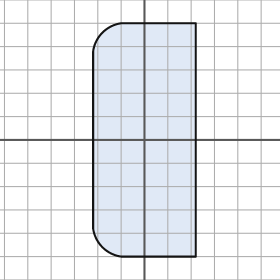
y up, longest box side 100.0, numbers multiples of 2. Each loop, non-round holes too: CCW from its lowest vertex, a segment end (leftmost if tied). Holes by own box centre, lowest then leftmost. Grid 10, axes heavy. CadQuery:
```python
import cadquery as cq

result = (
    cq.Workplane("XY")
    .moveTo(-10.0, -50.0)
    .lineTo(22.0, -50.0)
    .lineTo(22.0, 50.0)
    .lineTo(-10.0, 50.0)
    .threePointArc((-18.0, 46.0), (-22.0, 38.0))
    .lineTo(-22.0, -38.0)
    .threePointArc((-18.0, -46.0), (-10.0, -50.0))
    .close()
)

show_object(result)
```